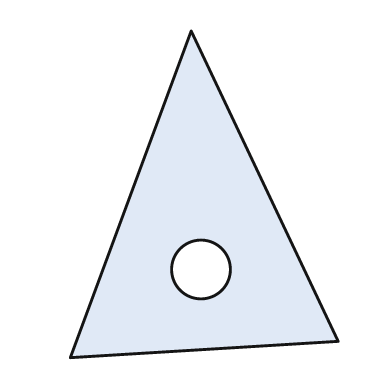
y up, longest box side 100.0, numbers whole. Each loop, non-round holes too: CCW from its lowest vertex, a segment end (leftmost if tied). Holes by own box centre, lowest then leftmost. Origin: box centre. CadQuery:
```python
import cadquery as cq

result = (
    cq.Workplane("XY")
    .moveTo(-41.0, -50.0)
    .lineTo(41.0, -45.0)
    .lineTo(-4.0, 50.0)
    .close()
    .moveTo(-1.0, -23.0)
    .circle(9.0)
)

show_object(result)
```